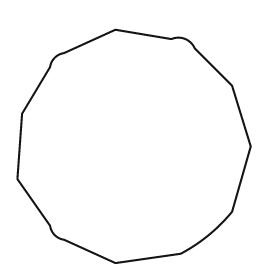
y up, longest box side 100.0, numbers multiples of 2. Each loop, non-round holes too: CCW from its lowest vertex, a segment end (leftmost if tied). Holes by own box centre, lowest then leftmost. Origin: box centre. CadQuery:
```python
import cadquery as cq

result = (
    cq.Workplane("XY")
    .moveTo(-8.0, -50.0)
    .lineTo(20.0, -46.0)
    .threePointArc((32.0, -38.0), (42.0, -28.0))
    .lineTo(50.0, 0.0)
    .lineTo(42.0, 26.0)
    .lineTo(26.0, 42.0)
    .threePointArc((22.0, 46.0), (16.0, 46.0))
    .lineTo(-8.0, 50.0)
    .lineTo(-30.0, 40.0)
    .threePointArc((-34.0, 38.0), (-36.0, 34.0))
    .lineTo(-48.0, 14.0)
    .lineTo(-50.0, -14.0)
    .lineTo(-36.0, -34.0)
    .threePointArc((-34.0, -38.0), (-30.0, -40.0))
    .close()
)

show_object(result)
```